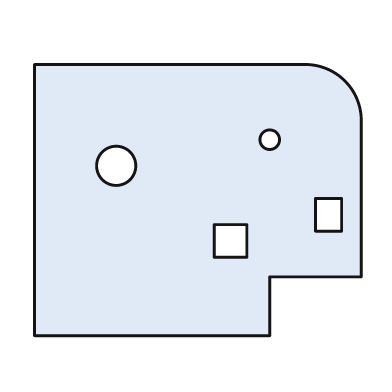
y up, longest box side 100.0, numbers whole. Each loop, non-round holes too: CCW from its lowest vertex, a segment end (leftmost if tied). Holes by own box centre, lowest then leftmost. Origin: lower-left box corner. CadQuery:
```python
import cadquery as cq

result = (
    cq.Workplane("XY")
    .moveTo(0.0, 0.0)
    .lineTo(72.0, 0.0)
    .lineTo(72.0, 18.0)
    .lineTo(100.0, 18.0)
    .lineTo(100.0, 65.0)
    .threePointArc((95.0, 78.0), (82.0, 83.0))
    .lineTo(0.0, 83.0)
    .close()
    .moveTo(55.0, 24.0)
    .lineTo(65.0, 24.0)
    .lineTo(65.0, 34.0)
    .lineTo(55.0, 34.0)
    .close()
    .moveTo(86.0, 32.0)
    .lineTo(94.0, 32.0)
    .lineTo(94.0, 42.0)
    .lineTo(86.0, 42.0)
    .close()
    .moveTo(25.0, 52.0)
    .circle(6.0)
    .moveTo(72.0, 60.0)
    .circle(3.0)
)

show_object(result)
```